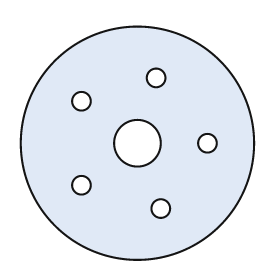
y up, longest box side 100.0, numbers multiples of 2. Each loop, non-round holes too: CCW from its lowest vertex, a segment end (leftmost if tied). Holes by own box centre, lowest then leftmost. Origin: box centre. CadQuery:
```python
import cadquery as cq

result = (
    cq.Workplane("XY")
    .moveTo(0.0, 0.0)
    .circle(50.0)
    .moveTo(10.0, -28.0)
    .circle(4.0)
    .moveTo(-24.0, -18.0)
    .circle(4.0)
    .moveTo(0.0, 0.0)
    .circle(10.0)
    .moveTo(30.0, 0.0)
    .circle(4.0)
    .moveTo(-24.0, 18.0)
    .circle(4.0)
    .moveTo(8.0, 28.0)
    .circle(4.0)
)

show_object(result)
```